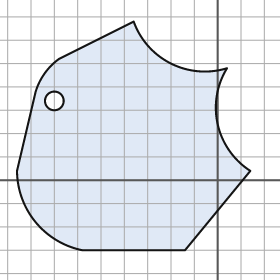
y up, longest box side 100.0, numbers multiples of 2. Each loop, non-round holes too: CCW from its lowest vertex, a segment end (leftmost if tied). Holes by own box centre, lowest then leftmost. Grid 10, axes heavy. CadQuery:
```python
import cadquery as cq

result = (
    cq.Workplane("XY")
    .moveTo(-58.0, -30.0)
    .lineTo(-14.0, -30.0)
    .lineTo(14.0, 4.0)
    .threePointArc((0.0, 24.0), (4.0, 48.0))
    .threePointArc((-20.0, 50.0), (-36.0, 68.0))
    .lineTo(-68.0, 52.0)
    .threePointArc((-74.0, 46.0), (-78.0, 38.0))
    .lineTo(-86.0, 4.0)
    .threePointArc((-78.0, -18.0), (-58.0, -30.0))
    .close()
    .moveTo(-70.0, 34.0)
    .circle(4.0)
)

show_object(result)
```